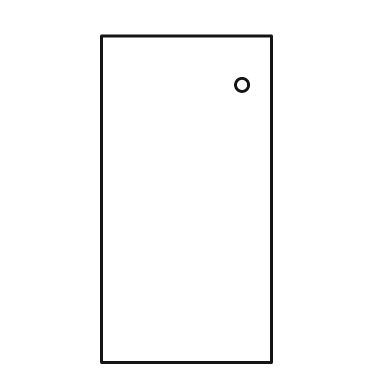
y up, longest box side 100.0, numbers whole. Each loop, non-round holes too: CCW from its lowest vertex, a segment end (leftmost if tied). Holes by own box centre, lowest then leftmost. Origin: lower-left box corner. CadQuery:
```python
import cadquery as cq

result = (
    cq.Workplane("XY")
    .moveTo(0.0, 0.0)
    .lineTo(52.0, 0.0)
    .lineTo(52.0, 100.0)
    .lineTo(0.0, 100.0)
    .close()
    .moveTo(43.0, 85.0)
    .circle(2.0)
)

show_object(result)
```